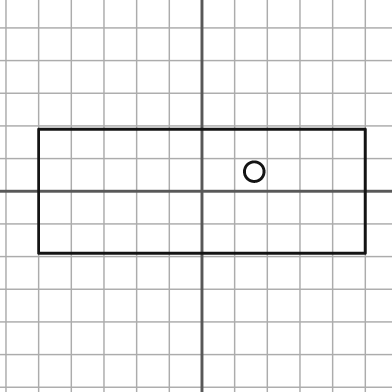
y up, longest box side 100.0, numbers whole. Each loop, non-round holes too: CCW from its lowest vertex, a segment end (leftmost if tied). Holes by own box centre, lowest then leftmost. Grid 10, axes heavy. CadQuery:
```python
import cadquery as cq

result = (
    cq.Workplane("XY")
    .moveTo(-50.0, -19.0)
    .lineTo(50.0, -19.0)
    .lineTo(50.0, 19.0)
    .lineTo(-50.0, 19.0)
    .close()
    .moveTo(16.0, 6.0)
    .circle(3.0)
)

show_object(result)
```